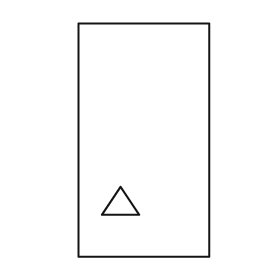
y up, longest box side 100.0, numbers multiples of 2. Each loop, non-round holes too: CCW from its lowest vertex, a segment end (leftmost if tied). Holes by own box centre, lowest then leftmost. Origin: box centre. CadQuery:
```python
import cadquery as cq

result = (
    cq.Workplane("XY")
    .moveTo(-28.0, -50.0)
    .lineTo(28.0, -50.0)
    .lineTo(28.0, 50.0)
    .lineTo(-28.0, 50.0)
    .close()
    .moveTo(-18.0, -32.0)
    .lineTo(-2.0, -32.0)
    .lineTo(-10.0, -20.0)
    .close()
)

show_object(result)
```